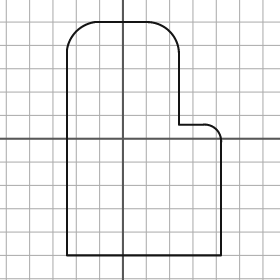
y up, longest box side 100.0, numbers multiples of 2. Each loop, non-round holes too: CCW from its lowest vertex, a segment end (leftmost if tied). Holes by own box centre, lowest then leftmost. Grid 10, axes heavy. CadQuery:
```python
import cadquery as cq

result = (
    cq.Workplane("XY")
    .moveTo(-24.0, -50.0)
    .lineTo(42.0, -50.0)
    .lineTo(42.0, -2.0)
    .threePointArc((40.0, 4.0), (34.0, 6.0))
    .lineTo(24.0, 6.0)
    .lineTo(24.0, 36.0)
    .threePointArc((20.0, 46.0), (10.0, 50.0))
    .lineTo(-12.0, 50.0)
    .threePointArc((-20.0, 46.0), (-24.0, 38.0))
    .close()
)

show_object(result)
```